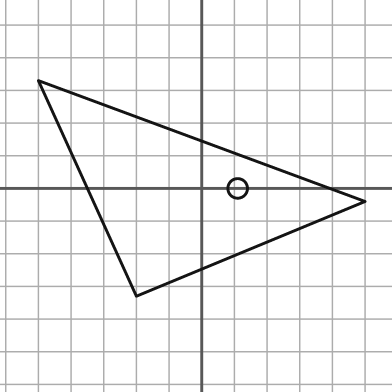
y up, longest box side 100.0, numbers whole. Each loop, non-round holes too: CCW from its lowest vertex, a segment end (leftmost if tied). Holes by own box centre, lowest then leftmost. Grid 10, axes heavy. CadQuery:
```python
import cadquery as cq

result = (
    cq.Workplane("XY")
    .moveTo(-20.0, -33.0)
    .lineTo(50.0, -4.0)
    .lineTo(-50.0, 33.0)
    .close()
    .moveTo(11.0, 0.0)
    .circle(3.0)
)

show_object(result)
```